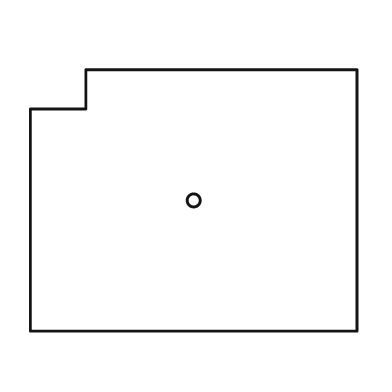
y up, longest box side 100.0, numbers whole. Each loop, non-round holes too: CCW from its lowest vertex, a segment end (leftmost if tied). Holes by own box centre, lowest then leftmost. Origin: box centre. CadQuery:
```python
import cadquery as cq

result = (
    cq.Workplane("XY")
    .moveTo(-50.0, -40.0)
    .lineTo(50.0, -40.0)
    .lineTo(50.0, 40.0)
    .lineTo(-33.0, 40.0)
    .lineTo(-33.0, 28.0)
    .lineTo(-50.0, 28.0)
    .close()
    .moveTo(0.0, 0.0)
    .circle(2.0)
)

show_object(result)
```